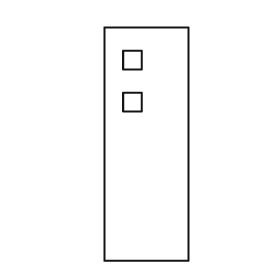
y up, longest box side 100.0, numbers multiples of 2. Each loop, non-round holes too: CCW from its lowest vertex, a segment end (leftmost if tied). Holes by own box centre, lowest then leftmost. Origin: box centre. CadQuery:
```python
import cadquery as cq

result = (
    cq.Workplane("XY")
    .moveTo(-18.0, -50.0)
    .lineTo(18.0, -50.0)
    .lineTo(18.0, 50.0)
    .lineTo(-18.0, 50.0)
    .close()
    .moveTo(-10.0, 14.0)
    .lineTo(-2.0, 14.0)
    .lineTo(-2.0, 22.0)
    .lineTo(-10.0, 22.0)
    .close()
    .moveTo(-10.0, 32.0)
    .lineTo(-2.0, 32.0)
    .lineTo(-2.0, 40.0)
    .lineTo(-10.0, 40.0)
    .close()
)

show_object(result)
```